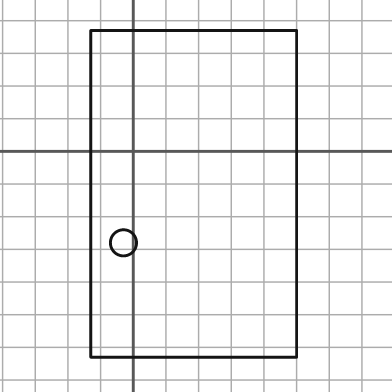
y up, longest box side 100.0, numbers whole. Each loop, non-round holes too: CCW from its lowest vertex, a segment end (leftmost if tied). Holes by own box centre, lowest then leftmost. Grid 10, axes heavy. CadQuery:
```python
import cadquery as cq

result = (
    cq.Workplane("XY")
    .moveTo(-13.0, -63.0)
    .lineTo(50.0, -63.0)
    .lineTo(50.0, 37.0)
    .lineTo(-13.0, 37.0)
    .close()
    .moveTo(-3.0, -28.0)
    .circle(4.0)
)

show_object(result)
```